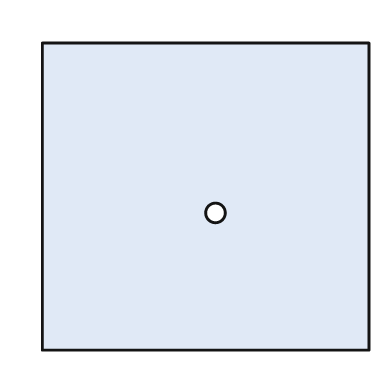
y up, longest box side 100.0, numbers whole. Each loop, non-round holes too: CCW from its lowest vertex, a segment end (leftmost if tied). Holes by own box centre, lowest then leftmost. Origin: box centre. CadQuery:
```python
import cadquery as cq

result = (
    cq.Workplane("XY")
    .moveTo(-50.0, -47.0)
    .lineTo(50.0, -47.0)
    .lineTo(50.0, 47.0)
    .lineTo(-50.0, 47.0)
    .close()
    .moveTo(3.0, -5.0)
    .circle(3.0)
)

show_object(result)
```